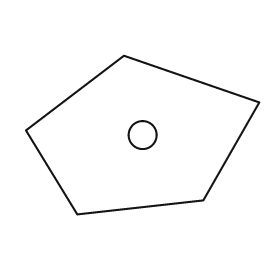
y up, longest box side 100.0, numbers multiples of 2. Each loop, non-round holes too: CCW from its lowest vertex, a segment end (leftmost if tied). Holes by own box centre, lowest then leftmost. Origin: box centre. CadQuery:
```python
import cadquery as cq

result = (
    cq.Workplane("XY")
    .moveTo(-28.0, -34.0)
    .lineTo(26.0, -28.0)
    .lineTo(50.0, 14.0)
    .lineTo(-8.0, 34.0)
    .lineTo(-50.0, 2.0)
    .close()
    .moveTo(0.0, 0.0)
    .circle(6.0)
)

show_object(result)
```